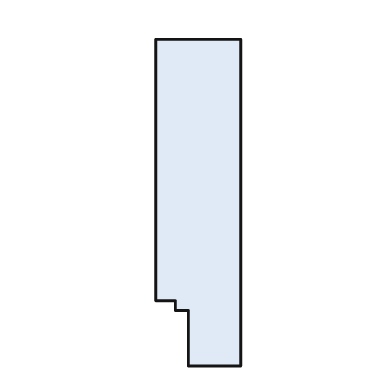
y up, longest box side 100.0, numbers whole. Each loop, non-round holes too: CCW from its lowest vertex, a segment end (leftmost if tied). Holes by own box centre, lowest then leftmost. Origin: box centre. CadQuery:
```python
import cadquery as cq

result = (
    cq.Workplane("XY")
    .moveTo(-3.0, -50.0)
    .lineTo(13.0, -50.0)
    .lineTo(13.0, 50.0)
    .lineTo(-13.0, 50.0)
    .lineTo(-13.0, -30.0)
    .lineTo(-7.0, -30.0)
    .lineTo(-7.0, -33.0)
    .lineTo(-3.0, -33.0)
    .close()
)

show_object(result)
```